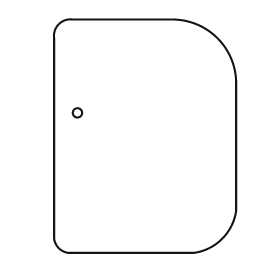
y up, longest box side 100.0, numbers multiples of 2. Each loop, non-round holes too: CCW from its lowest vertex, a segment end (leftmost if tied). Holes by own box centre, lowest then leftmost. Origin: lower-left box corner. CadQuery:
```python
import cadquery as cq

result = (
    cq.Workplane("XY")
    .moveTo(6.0, 0.0)
    .lineTo(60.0, 0.0)
    .threePointArc((72.0, 6.0), (78.0, 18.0))
    .lineTo(78.0, 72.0)
    .threePointArc((70.0, 92.0), (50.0, 100.0))
    .lineTo(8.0, 100.0)
    .threePointArc((2.0, 98.0), (0.0, 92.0))
    .lineTo(0.0, 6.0)
    .threePointArc((2.0, 2.0), (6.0, 0.0))
    .close()
    .moveTo(10.0, 60.0)
    .circle(2.0)
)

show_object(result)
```